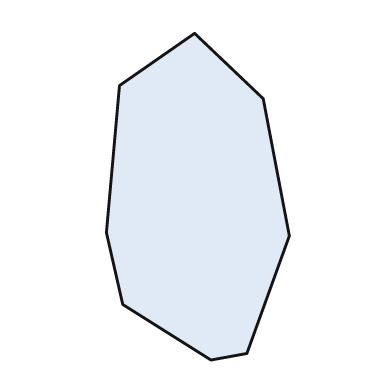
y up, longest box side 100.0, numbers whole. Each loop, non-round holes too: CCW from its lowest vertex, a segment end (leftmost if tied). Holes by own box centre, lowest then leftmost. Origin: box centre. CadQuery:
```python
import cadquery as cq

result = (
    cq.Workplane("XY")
    .moveTo(4.0, -50.0)
    .lineTo(15.0, -48.0)
    .lineTo(28.0, -12.0)
    .lineTo(20.0, 30.0)
    .lineTo(-1.0, 50.0)
    .lineTo(-24.0, 34.0)
    .lineTo(-28.0, -11.0)
    .lineTo(-23.0, -33.0)
    .close()
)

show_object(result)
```